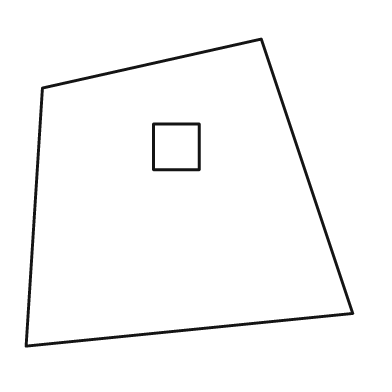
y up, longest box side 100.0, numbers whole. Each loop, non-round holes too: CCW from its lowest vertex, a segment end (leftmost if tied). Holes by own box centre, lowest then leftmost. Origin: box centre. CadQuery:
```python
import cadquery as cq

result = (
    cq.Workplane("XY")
    .moveTo(-50.0, -47.0)
    .lineTo(50.0, -37.0)
    .lineTo(22.0, 47.0)
    .lineTo(-45.0, 32.0)
    .close()
    .moveTo(-11.0, 7.0)
    .lineTo(3.0, 7.0)
    .lineTo(3.0, 21.0)
    .lineTo(-11.0, 21.0)
    .close()
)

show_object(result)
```